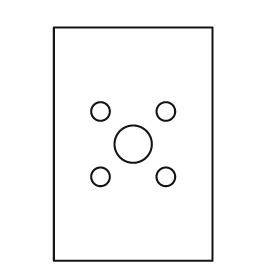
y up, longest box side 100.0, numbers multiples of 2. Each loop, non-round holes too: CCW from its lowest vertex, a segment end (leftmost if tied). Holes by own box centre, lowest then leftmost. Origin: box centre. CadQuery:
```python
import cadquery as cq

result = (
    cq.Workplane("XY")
    .moveTo(-34.0, -50.0)
    .lineTo(34.0, -50.0)
    .lineTo(34.0, 50.0)
    .lineTo(-34.0, 50.0)
    .close()
    .moveTo(-14.0, -14.0)
    .circle(4.0)
    .moveTo(14.0, -14.0)
    .circle(4.0)
    .moveTo(0.0, 0.0)
    .circle(8.0)
    .moveTo(-14.0, 14.0)
    .circle(4.0)
    .moveTo(14.0, 14.0)
    .circle(4.0)
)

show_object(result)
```